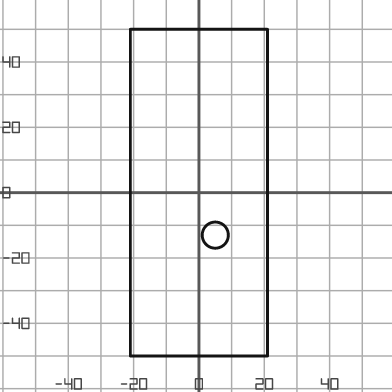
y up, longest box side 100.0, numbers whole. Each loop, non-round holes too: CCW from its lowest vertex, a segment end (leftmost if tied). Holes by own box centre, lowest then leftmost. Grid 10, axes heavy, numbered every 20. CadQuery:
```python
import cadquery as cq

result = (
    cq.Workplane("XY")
    .moveTo(-21.0, -50.0)
    .lineTo(21.0, -50.0)
    .lineTo(21.0, 50.0)
    .lineTo(-21.0, 50.0)
    .close()
    .moveTo(5.0, -13.0)
    .circle(4.0)
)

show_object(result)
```